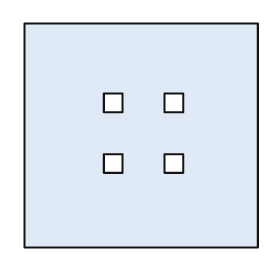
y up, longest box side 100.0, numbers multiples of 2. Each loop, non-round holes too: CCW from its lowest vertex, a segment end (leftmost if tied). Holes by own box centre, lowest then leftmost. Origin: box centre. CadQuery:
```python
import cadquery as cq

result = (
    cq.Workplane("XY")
    .moveTo(-50.0, -48.0)
    .lineTo(50.0, -48.0)
    .lineTo(50.0, 48.0)
    .lineTo(-50.0, 48.0)
    .close()
    .moveTo(-16.0, -16.0)
    .lineTo(-8.0, -16.0)
    .lineTo(-8.0, -8.0)
    .lineTo(-16.0, -8.0)
    .close()
    .moveTo(10.0, -16.0)
    .lineTo(18.0, -16.0)
    .lineTo(18.0, -8.0)
    .lineTo(10.0, -8.0)
    .close()
    .moveTo(-16.0, 10.0)
    .lineTo(-8.0, 10.0)
    .lineTo(-8.0, 18.0)
    .lineTo(-16.0, 18.0)
    .close()
    .moveTo(10.0, 10.0)
    .lineTo(18.0, 10.0)
    .lineTo(18.0, 18.0)
    .lineTo(10.0, 18.0)
    .close()
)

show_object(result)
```